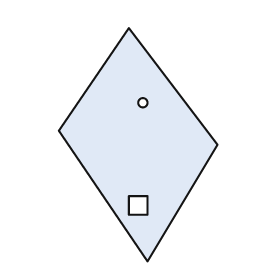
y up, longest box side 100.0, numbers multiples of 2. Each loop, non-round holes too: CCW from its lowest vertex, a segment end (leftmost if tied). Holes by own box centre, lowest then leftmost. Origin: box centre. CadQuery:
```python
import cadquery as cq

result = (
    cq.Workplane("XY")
    .moveTo(4.0, -50.0)
    .lineTo(34.0, 0.0)
    .lineTo(-4.0, 50.0)
    .lineTo(-34.0, 6.0)
    .close()
    .moveTo(-4.0, -30.0)
    .lineTo(4.0, -30.0)
    .lineTo(4.0, -22.0)
    .lineTo(-4.0, -22.0)
    .close()
    .moveTo(2.0, 18.0)
    .circle(2.0)
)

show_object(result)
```